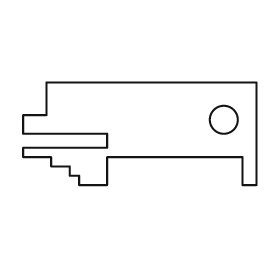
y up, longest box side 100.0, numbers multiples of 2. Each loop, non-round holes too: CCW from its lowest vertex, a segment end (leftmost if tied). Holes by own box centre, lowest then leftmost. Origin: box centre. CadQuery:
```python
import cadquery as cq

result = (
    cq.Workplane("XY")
    .moveTo(-26.0, -22.0)
    .lineTo(-14.0, -22.0)
    .lineTo(-14.0, -10.0)
    .lineTo(44.0, -10.0)
    .lineTo(44.0, -22.0)
    .lineTo(50.0, -22.0)
    .lineTo(50.0, 22.0)
    .lineTo(-40.0, 22.0)
    .lineTo(-40.0, 8.0)
    .lineTo(-50.0, 8.0)
    .lineTo(-50.0, 0.0)
    .lineTo(-14.0, 0.0)
    .lineTo(-14.0, -6.0)
    .lineTo(-50.0, -6.0)
    .lineTo(-50.0, -10.0)
    .lineTo(-38.0, -10.0)
    .lineTo(-38.0, -14.0)
    .lineTo(-30.0, -14.0)
    .lineTo(-30.0, -18.0)
    .lineTo(-26.0, -18.0)
    .close()
    .moveTo(36.0, 6.0)
    .circle(6.0)
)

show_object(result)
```